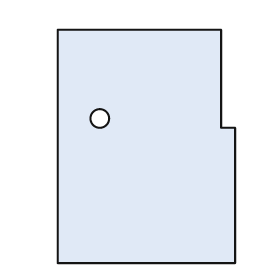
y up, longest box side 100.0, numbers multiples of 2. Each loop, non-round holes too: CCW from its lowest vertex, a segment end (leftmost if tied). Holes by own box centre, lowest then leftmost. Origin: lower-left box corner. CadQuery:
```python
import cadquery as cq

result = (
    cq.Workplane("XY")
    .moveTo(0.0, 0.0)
    .lineTo(76.0, 0.0)
    .lineTo(76.0, 58.0)
    .lineTo(70.0, 58.0)
    .lineTo(70.0, 100.0)
    .lineTo(0.0, 100.0)
    .close()
    .moveTo(18.0, 62.0)
    .circle(4.0)
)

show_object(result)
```